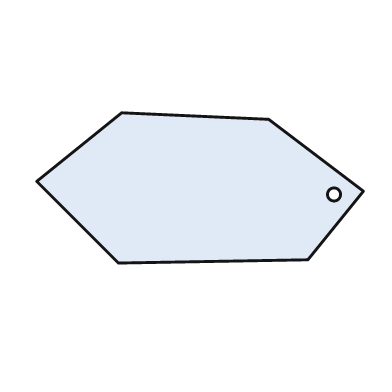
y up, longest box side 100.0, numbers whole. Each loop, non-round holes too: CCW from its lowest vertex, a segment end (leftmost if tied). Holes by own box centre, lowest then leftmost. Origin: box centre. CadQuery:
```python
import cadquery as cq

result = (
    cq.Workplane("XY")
    .moveTo(-25.0, -23.0)
    .lineTo(33.0, -22.0)
    .lineTo(50.0, -1.0)
    .lineTo(21.0, 21.0)
    .lineTo(-24.0, 23.0)
    .lineTo(-50.0, 2.0)
    .close()
    .moveTo(41.0, -2.0)
    .circle(2.0)
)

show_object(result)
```